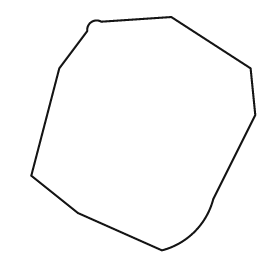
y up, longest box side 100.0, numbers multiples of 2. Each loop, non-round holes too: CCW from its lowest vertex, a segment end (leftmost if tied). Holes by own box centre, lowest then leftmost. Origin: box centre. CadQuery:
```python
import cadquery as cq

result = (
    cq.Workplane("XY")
    .moveTo(8.0, -50.0)
    .threePointArc((22.0, -42.0), (30.0, -28.0))
    .lineTo(48.0, 8.0)
    .lineTo(46.0, 28.0)
    .lineTo(12.0, 50.0)
    .lineTo(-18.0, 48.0)
    .threePointArc((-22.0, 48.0), (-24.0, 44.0))
    .lineTo(-36.0, 28.0)
    .lineTo(-48.0, -18.0)
    .lineTo(-28.0, -34.0)
    .close()
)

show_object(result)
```